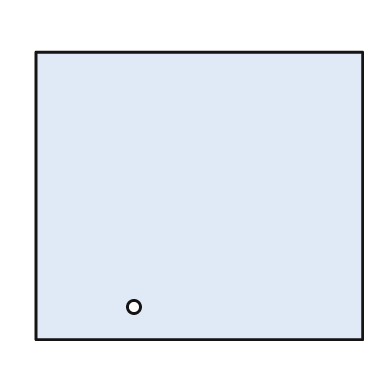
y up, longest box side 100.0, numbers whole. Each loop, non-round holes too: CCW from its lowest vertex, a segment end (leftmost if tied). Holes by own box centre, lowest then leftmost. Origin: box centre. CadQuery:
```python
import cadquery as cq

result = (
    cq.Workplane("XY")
    .moveTo(-50.0, -44.0)
    .lineTo(50.0, -44.0)
    .lineTo(50.0, 44.0)
    .lineTo(-50.0, 44.0)
    .close()
    .moveTo(-20.0, -34.0)
    .circle(2.0)
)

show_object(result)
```